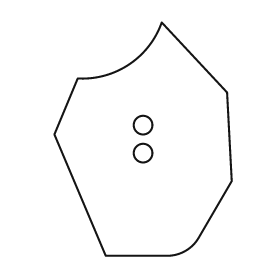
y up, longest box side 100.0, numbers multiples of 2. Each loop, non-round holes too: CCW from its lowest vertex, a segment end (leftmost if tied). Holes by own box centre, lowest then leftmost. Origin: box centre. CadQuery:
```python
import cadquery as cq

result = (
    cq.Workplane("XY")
    .moveTo(-16.0, -50.0)
    .lineTo(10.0, -50.0)
    .threePointArc((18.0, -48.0), (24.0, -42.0))
    .lineTo(38.0, -18.0)
    .lineTo(36.0, 20.0)
    .lineTo(8.0, 50.0)
    .threePointArc((-6.0, 32.0), (-28.0, 26.0))
    .lineTo(-38.0, 2.0)
    .close()
    .moveTo(0.0, -6.0)
    .circle(4.0)
    .moveTo(0.0, 6.0)
    .circle(4.0)
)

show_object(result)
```